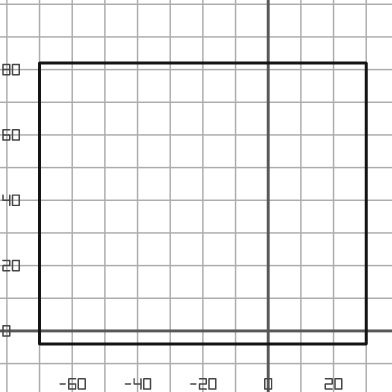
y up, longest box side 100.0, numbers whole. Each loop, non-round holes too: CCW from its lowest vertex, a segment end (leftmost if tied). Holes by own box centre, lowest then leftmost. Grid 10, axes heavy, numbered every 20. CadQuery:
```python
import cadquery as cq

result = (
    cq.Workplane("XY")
    .moveTo(-70.0, -4.0)
    .lineTo(30.0, -4.0)
    .lineTo(30.0, 82.0)
    .lineTo(-70.0, 82.0)
    .close()
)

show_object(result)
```